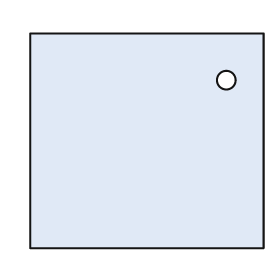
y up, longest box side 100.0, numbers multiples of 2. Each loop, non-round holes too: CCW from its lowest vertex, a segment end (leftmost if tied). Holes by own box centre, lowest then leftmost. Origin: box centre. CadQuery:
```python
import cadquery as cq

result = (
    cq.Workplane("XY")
    .moveTo(-50.0, -46.0)
    .lineTo(50.0, -46.0)
    .lineTo(50.0, 46.0)
    .lineTo(-50.0, 46.0)
    .close()
    .moveTo(34.0, 26.0)
    .circle(4.0)
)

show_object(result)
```